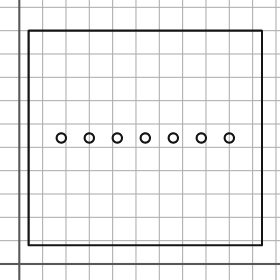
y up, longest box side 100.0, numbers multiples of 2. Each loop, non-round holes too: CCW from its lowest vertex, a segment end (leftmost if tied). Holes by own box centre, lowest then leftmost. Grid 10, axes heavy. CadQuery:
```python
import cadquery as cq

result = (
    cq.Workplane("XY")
    .moveTo(4.0, 8.0)
    .lineTo(104.0, 8.0)
    .lineTo(104.0, 100.0)
    .lineTo(4.0, 100.0)
    .close()
    .moveTo(18.0, 54.0)
    .circle(2.0)
    .moveTo(30.0, 54.0)
    .circle(2.0)
    .moveTo(42.0, 54.0)
    .circle(2.0)
    .moveTo(54.0, 54.0)
    .circle(2.0)
    .moveTo(66.0, 54.0)
    .circle(2.0)
    .moveTo(78.0, 54.0)
    .circle(2.0)
    .moveTo(90.0, 54.0)
    .circle(2.0)
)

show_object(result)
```